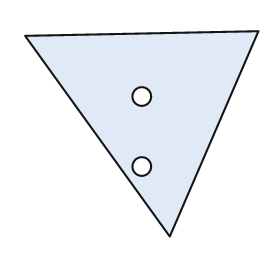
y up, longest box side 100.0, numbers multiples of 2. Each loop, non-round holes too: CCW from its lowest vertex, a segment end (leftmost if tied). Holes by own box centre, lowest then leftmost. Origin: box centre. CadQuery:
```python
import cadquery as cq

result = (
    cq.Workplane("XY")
    .moveTo(12.0, -44.0)
    .lineTo(50.0, 44.0)
    .lineTo(-50.0, 42.0)
    .close()
    .moveTo(0.0, -14.0)
    .circle(4.0)
    .moveTo(0.0, 16.0)
    .circle(4.0)
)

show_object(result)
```